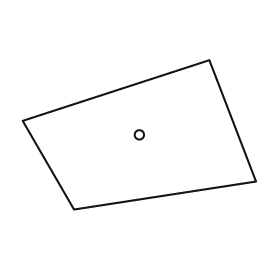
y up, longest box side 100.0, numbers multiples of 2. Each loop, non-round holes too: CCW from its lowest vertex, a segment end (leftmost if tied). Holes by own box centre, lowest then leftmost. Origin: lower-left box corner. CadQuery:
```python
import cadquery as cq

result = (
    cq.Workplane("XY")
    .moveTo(22.0, 0.0)
    .lineTo(100.0, 12.0)
    .lineTo(80.0, 64.0)
    .lineTo(0.0, 38.0)
    .close()
    .moveTo(50.0, 32.0)
    .circle(2.0)
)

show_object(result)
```